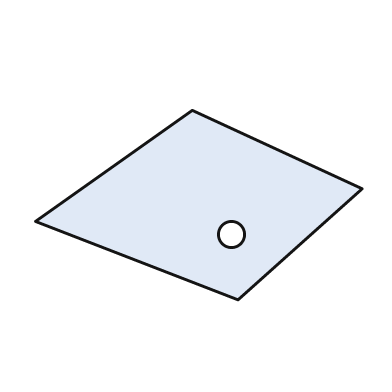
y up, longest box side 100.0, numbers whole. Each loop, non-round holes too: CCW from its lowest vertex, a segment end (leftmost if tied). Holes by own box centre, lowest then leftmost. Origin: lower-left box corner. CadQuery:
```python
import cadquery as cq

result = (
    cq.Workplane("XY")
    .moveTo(62.0, 0.0)
    .lineTo(100.0, 34.0)
    .lineTo(48.0, 58.0)
    .lineTo(0.0, 24.0)
    .close()
    .moveTo(60.0, 20.0)
    .circle(4.0)
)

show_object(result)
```